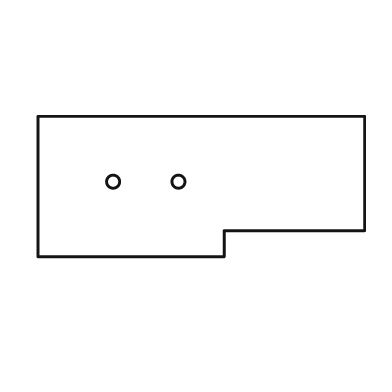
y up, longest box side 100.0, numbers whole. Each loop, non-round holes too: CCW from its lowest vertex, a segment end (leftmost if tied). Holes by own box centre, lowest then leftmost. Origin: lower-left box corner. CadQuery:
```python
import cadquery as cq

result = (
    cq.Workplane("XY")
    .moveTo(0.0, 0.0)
    .lineTo(57.0, 0.0)
    .lineTo(57.0, 8.0)
    .lineTo(100.0, 8.0)
    .lineTo(100.0, 43.0)
    .lineTo(0.0, 43.0)
    .close()
    .moveTo(23.0, 23.0)
    .circle(2.0)
    .moveTo(43.0, 23.0)
    .circle(2.0)
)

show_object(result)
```